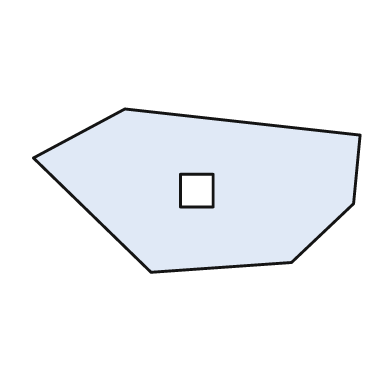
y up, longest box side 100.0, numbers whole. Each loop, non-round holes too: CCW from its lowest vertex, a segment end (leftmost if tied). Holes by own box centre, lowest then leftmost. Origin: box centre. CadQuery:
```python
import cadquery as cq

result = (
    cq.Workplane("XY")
    .moveTo(-14.0, -25.0)
    .lineTo(29.0, -22.0)
    .lineTo(48.0, -4.0)
    .lineTo(50.0, 17.0)
    .lineTo(-22.0, 25.0)
    .lineTo(-50.0, 10.0)
    .close()
    .moveTo(-5.0, -5.0)
    .lineTo(5.0, -5.0)
    .lineTo(5.0, 5.0)
    .lineTo(-5.0, 5.0)
    .close()
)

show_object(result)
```